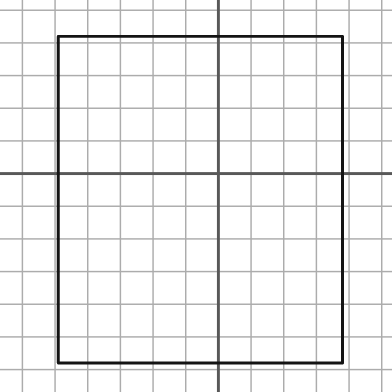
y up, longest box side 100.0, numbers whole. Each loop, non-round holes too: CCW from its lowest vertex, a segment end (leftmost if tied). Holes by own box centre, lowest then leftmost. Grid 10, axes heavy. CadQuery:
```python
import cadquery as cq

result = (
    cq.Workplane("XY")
    .moveTo(-49.0, -58.0)
    .lineTo(38.0, -58.0)
    .lineTo(38.0, 42.0)
    .lineTo(-49.0, 42.0)
    .close()
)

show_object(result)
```